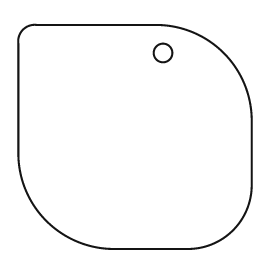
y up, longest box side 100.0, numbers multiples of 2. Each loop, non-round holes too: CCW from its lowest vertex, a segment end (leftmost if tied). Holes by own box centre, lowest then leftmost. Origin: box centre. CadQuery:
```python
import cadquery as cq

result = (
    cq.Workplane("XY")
    .moveTo(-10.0, -48.0)
    .lineTo(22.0, -48.0)
    .threePointArc((42.0, -40.0), (50.0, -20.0))
    .lineTo(50.0, 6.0)
    .threePointArc((38.0, 36.0), (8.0, 48.0))
    .lineTo(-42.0, 48.0)
    .threePointArc((-48.0, 46.0), (-50.0, 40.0))
    .lineTo(-50.0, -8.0)
    .threePointArc((-38.0, -36.0), (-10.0, -48.0))
    .close()
    .moveTo(12.0, 36.0)
    .circle(4.0)
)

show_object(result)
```